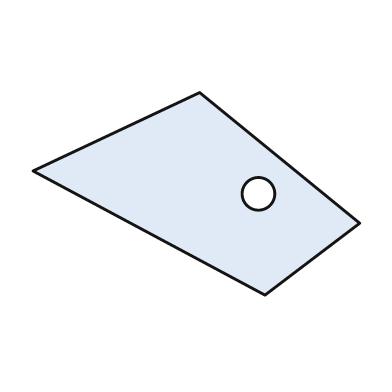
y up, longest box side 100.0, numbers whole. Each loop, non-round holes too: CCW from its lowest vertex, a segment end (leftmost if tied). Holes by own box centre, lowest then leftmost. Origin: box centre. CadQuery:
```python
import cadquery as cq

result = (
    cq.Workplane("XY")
    .moveTo(21.0, -31.0)
    .lineTo(50.0, -9.0)
    .lineTo(1.0, 31.0)
    .lineTo(-50.0, 7.0)
    .close()
    .moveTo(19.0, 0.0)
    .circle(5.0)
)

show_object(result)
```